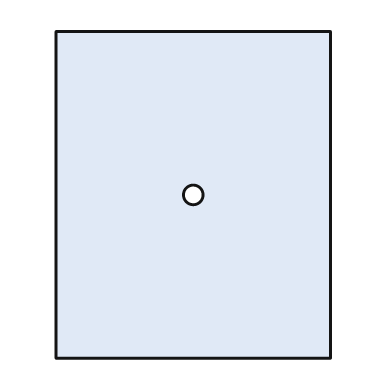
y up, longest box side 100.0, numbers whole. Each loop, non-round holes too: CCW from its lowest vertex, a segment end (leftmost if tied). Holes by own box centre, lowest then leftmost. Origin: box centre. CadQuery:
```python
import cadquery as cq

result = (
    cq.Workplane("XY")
    .moveTo(-42.0, -50.0)
    .lineTo(42.0, -50.0)
    .lineTo(42.0, 50.0)
    .lineTo(-42.0, 50.0)
    .close()
    .moveTo(0.0, 0.0)
    .circle(3.0)
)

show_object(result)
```